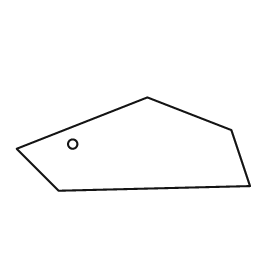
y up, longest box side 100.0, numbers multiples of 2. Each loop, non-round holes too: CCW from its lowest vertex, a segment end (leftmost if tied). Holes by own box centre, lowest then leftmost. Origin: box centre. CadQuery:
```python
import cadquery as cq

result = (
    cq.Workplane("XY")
    .moveTo(-32.0, -20.0)
    .lineTo(50.0, -18.0)
    .lineTo(42.0, 6.0)
    .lineTo(6.0, 20.0)
    .lineTo(-50.0, -2.0)
    .close()
    .moveTo(-26.0, 0.0)
    .circle(2.0)
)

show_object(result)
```